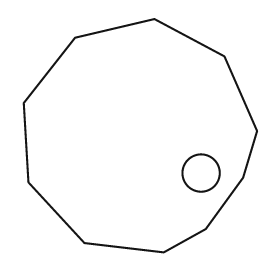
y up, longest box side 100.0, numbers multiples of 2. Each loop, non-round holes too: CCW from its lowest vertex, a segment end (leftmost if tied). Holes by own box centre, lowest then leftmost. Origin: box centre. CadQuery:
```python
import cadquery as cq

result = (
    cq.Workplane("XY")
    .moveTo(10.0, -50.0)
    .lineTo(28.0, -40.0)
    .lineTo(44.0, -18.0)
    .lineTo(50.0, 2.0)
    .lineTo(36.0, 34.0)
    .lineTo(6.0, 50.0)
    .lineTo(-28.0, 42.0)
    .lineTo(-50.0, 14.0)
    .lineTo(-48.0, -20.0)
    .lineTo(-24.0, -46.0)
    .close()
    .moveTo(26.0, -16.0)
    .circle(8.0)
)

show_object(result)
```